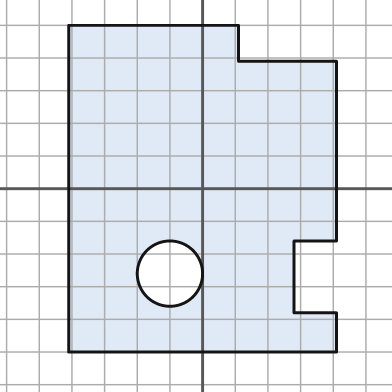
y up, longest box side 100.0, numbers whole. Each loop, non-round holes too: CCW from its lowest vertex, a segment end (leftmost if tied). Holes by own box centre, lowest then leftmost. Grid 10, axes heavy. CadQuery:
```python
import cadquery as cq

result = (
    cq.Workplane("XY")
    .moveTo(-41.0, -50.0)
    .lineTo(41.0, -50.0)
    .lineTo(41.0, -38.0)
    .lineTo(28.0, -38.0)
    .lineTo(28.0, -16.0)
    .lineTo(41.0, -16.0)
    .lineTo(41.0, 39.0)
    .lineTo(11.0, 39.0)
    .lineTo(11.0, 50.0)
    .lineTo(-41.0, 50.0)
    .close()
    .moveTo(-10.0, -26.0)
    .circle(10.0)
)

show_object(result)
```